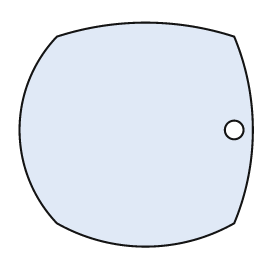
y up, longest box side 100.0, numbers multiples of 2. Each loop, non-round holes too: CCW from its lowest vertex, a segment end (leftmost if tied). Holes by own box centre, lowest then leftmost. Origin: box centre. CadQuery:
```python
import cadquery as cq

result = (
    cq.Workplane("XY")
    .moveTo(-34.0, -38.0)
    .threePointArc((4.0, -48.0), (42.0, -38.0))
    .threePointArc((50.0, 2.0), (42.0, 42.0))
    .threePointArc((4.0, 48.0), (-34.0, 42.0))
    .threePointArc((-50.0, 2.0), (-34.0, -38.0))
    .close()
    .moveTo(42.0, 2.0)
    .circle(4.0)
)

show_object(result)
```